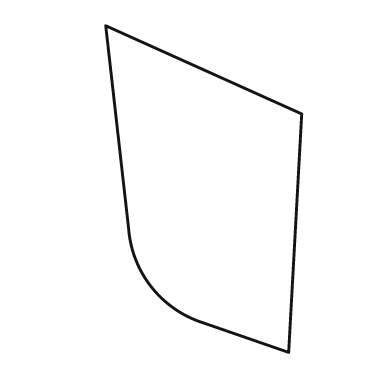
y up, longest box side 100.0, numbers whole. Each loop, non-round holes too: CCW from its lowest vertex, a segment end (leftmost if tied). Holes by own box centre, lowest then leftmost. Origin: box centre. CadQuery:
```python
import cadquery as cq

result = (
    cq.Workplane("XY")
    .moveTo(26.0, -50.0)
    .lineTo(30.0, 23.0)
    .lineTo(-30.0, 50.0)
    .lineTo(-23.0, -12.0)
    .threePointArc((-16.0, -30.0), (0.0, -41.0))
    .close()
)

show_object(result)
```